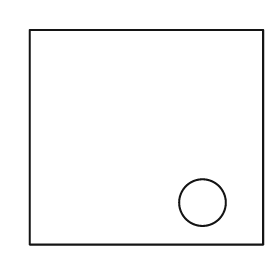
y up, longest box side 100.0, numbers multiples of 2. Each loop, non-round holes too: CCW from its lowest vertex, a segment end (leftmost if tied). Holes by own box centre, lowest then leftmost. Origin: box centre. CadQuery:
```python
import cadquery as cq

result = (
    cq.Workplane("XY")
    .moveTo(-50.0, -46.0)
    .lineTo(50.0, -46.0)
    .lineTo(50.0, 46.0)
    .lineTo(-50.0, 46.0)
    .close()
    .moveTo(24.0, -28.0)
    .circle(10.0)
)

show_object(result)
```